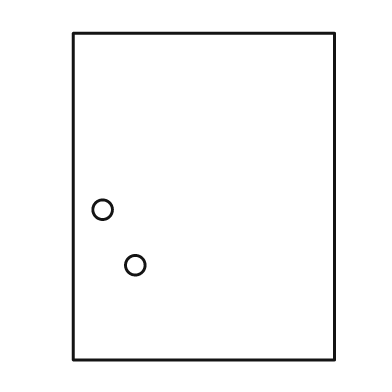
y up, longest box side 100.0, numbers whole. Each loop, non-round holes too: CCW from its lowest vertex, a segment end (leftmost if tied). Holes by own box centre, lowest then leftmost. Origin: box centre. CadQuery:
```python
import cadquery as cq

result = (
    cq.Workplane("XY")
    .moveTo(-40.0, -50.0)
    .lineTo(40.0, -50.0)
    .lineTo(40.0, 50.0)
    .lineTo(-40.0, 50.0)
    .close()
    .moveTo(-21.0, -21.0)
    .circle(3.0)
    .moveTo(-31.0, -4.0)
    .circle(3.0)
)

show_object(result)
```